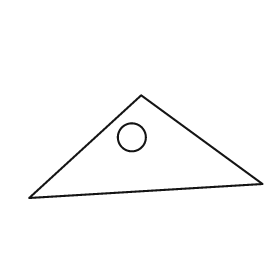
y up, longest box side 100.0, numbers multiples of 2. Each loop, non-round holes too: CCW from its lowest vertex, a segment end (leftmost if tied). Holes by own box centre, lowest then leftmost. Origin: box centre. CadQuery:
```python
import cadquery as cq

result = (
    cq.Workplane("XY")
    .moveTo(-50.0, -22.0)
    .lineTo(50.0, -16.0)
    .lineTo(-2.0, 22.0)
    .close()
    .moveTo(-6.0, 4.0)
    .circle(6.0)
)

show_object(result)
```